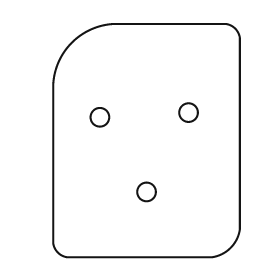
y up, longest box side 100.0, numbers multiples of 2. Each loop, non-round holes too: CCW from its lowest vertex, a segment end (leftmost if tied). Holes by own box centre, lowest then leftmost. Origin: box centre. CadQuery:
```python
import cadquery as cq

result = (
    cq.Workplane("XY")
    .moveTo(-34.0, -50.0)
    .lineTo(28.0, -50.0)
    .threePointArc((36.0, -46.0), (40.0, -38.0))
    .lineTo(40.0, 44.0)
    .threePointArc((38.0, 48.0), (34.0, 50.0))
    .lineTo(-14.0, 50.0)
    .threePointArc((-32.0, 42.0), (-40.0, 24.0))
    .lineTo(-40.0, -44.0)
    .threePointArc((-38.0, -48.0), (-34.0, -50.0))
    .close()
    .moveTo(0.0, -22.0)
    .circle(4.0)
    .moveTo(-20.0, 10.0)
    .circle(4.0)
    .moveTo(18.0, 12.0)
    .circle(4.0)
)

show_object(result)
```